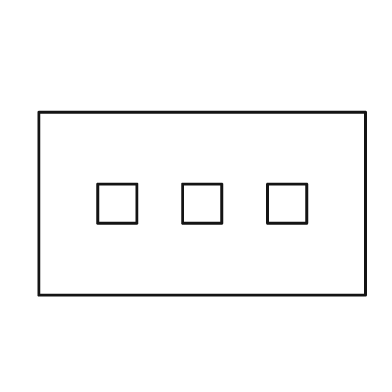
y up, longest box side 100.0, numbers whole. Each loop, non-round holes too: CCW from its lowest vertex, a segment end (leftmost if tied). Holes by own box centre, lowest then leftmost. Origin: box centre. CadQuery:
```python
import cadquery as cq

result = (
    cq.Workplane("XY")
    .moveTo(-50.0, -28.0)
    .lineTo(50.0, -28.0)
    .lineTo(50.0, 28.0)
    .lineTo(-50.0, 28.0)
    .close()
    .moveTo(-32.0, -6.0)
    .lineTo(-20.0, -6.0)
    .lineTo(-20.0, 6.0)
    .lineTo(-32.0, 6.0)
    .close()
    .moveTo(-6.0, -6.0)
    .lineTo(6.0, -6.0)
    .lineTo(6.0, 6.0)
    .lineTo(-6.0, 6.0)
    .close()
    .moveTo(20.0, -6.0)
    .lineTo(32.0, -6.0)
    .lineTo(32.0, 6.0)
    .lineTo(20.0, 6.0)
    .close()
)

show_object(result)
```